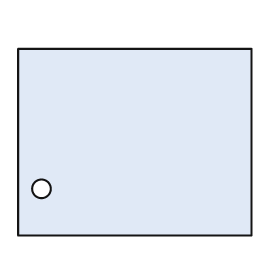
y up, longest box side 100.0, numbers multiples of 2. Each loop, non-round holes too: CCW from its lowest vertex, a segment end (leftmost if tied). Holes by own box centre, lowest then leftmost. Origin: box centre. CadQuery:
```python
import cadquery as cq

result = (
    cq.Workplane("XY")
    .moveTo(-50.0, -40.0)
    .lineTo(50.0, -40.0)
    .lineTo(50.0, 40.0)
    .lineTo(-50.0, 40.0)
    .close()
    .moveTo(-40.0, -20.0)
    .circle(4.0)
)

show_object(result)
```